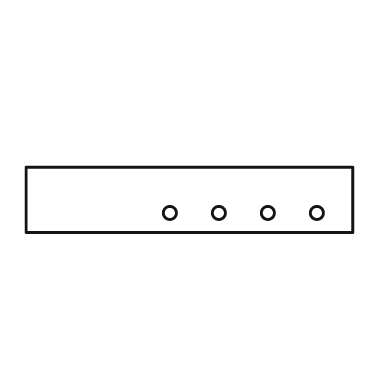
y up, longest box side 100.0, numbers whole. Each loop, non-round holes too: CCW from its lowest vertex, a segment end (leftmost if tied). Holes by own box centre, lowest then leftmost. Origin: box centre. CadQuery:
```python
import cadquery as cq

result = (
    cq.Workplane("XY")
    .moveTo(-50.0, -10.0)
    .lineTo(50.0, -10.0)
    .lineTo(50.0, 10.0)
    .lineTo(-50.0, 10.0)
    .close()
    .moveTo(-6.0, -4.0)
    .circle(2.0)
    .moveTo(9.0, -4.0)
    .circle(2.0)
    .moveTo(24.0, -4.0)
    .circle(2.0)
    .moveTo(39.0, -4.0)
    .circle(2.0)
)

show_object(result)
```